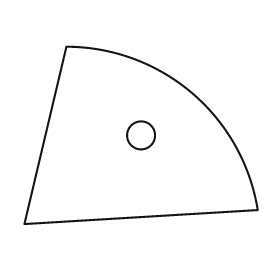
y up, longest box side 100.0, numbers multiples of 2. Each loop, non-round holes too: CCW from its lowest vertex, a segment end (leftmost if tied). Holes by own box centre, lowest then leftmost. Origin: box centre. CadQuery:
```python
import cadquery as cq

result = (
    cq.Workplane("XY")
    .moveTo(-50.0, -38.0)
    .lineTo(50.0, -32.0)
    .threePointArc((22.0, 18.0), (-32.0, 38.0))
    .close()
    .moveTo(0.0, 0.0)
    .circle(6.0)
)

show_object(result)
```